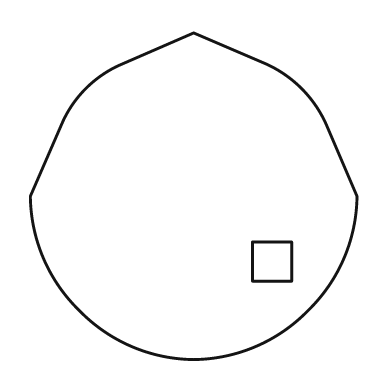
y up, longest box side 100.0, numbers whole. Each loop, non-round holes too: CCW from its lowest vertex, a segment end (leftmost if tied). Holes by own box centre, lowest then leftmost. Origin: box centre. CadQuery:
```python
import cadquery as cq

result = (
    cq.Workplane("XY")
    .moveTo(0.0, -50.0)
    .threePointArc((19.0, -46.0), (35.0, -35.0))
    .threePointArc((46.0, -19.0), (50.0, 0.0))
    .lineTo(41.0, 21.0)
    .threePointArc((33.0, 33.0), (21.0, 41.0))
    .lineTo(0.0, 50.0)
    .lineTo(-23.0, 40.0)
    .threePointArc((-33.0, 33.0), (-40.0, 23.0))
    .lineTo(-50.0, 0.0)
    .threePointArc((-46.0, -19.0), (-35.0, -35.0))
    .threePointArc((-19.0, -46.0), (0.0, -50.0))
    .close()
    .moveTo(18.0, -26.0)
    .lineTo(30.0, -26.0)
    .lineTo(30.0, -14.0)
    .lineTo(18.0, -14.0)
    .close()
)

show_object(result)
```